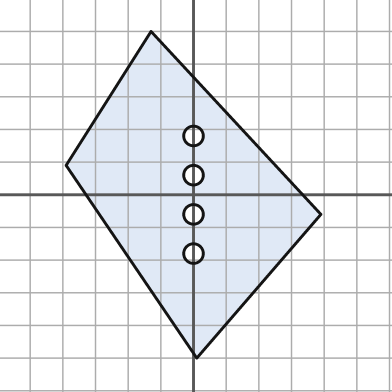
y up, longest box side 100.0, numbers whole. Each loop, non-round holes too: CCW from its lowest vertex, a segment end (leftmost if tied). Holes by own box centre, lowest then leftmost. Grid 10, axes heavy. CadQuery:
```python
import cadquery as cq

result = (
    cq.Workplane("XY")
    .moveTo(1.0, -50.0)
    .lineTo(39.0, -6.0)
    .lineTo(-13.0, 50.0)
    .lineTo(-39.0, 9.0)
    .close()
    .moveTo(0.0, -18.0)
    .circle(3.0)
    .moveTo(0.0, -6.0)
    .circle(3.0)
    .moveTo(0.0, 6.0)
    .circle(3.0)
    .moveTo(0.0, 18.0)
    .circle(3.0)
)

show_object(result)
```